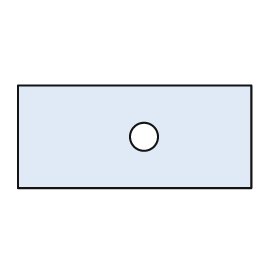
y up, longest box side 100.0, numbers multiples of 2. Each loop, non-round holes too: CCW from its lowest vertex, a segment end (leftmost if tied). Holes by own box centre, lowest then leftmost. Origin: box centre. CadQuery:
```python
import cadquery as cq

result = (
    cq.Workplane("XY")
    .moveTo(-50.0, -22.0)
    .lineTo(50.0, -22.0)
    .lineTo(50.0, 22.0)
    .lineTo(-50.0, 22.0)
    .close()
    .moveTo(4.0, 0.0)
    .circle(6.0)
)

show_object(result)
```